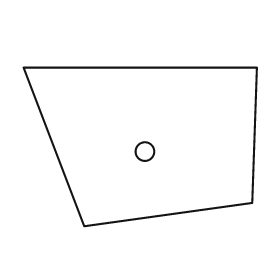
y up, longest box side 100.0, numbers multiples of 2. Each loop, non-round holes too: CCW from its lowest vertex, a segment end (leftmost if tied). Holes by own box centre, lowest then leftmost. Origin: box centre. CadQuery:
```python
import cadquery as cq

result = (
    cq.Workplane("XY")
    .moveTo(-24.0, -34.0)
    .lineTo(48.0, -24.0)
    .lineTo(50.0, 34.0)
    .lineTo(-50.0, 34.0)
    .close()
    .moveTo(2.0, -2.0)
    .circle(4.0)
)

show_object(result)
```